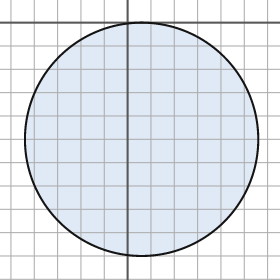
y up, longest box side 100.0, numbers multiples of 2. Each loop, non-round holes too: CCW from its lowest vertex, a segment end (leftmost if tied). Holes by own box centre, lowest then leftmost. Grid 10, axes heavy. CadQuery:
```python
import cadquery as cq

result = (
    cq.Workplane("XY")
    .moveTo(6.0, -50.0)
    .circle(50.0)
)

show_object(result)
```